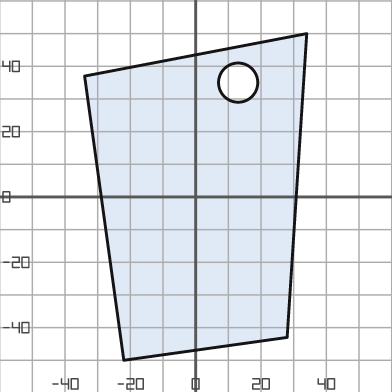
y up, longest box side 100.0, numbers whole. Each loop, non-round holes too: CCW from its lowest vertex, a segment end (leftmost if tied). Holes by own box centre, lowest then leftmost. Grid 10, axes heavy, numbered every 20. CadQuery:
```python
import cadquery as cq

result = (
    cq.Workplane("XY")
    .moveTo(-22.0, -50.0)
    .lineTo(28.0, -43.0)
    .lineTo(34.0, 50.0)
    .lineTo(-34.0, 37.0)
    .close()
    .moveTo(13.0, 35.0)
    .circle(6.0)
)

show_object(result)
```